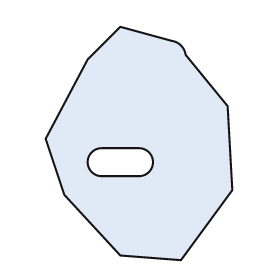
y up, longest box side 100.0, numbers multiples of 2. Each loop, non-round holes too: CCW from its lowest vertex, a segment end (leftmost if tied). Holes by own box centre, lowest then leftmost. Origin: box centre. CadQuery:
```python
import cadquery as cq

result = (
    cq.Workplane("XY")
    .moveTo(18.0, -50.0)
    .lineTo(40.0, -20.0)
    .lineTo(38.0, 16.0)
    .lineTo(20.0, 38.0)
    .threePointArc((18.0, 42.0), (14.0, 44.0))
    .lineTo(-8.0, 50.0)
    .lineTo(-22.0, 36.0)
    .lineTo(-40.0, 2.0)
    .lineTo(-32.0, -22.0)
    .lineTo(-8.0, -48.0)
    .close()
    .moveTo(-16.0, -14.0)
    .lineTo(0.0, -14.0)
    .threePointArc((6.0, -8.0), (0.0, -2.0))
    .lineTo(-16.0, -2.0)
    .threePointArc((-22.0, -8.0), (-16.0, -14.0))
    .close()
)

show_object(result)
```